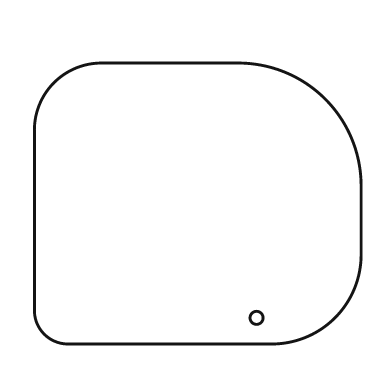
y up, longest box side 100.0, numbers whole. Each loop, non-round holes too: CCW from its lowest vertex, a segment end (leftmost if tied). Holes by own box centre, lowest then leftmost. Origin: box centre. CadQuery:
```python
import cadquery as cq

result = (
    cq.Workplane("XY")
    .moveTo(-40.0, -43.0)
    .lineTo(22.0, -43.0)
    .threePointArc((42.0, -35.0), (50.0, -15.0))
    .lineTo(50.0, 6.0)
    .threePointArc((39.0, 32.0), (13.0, 43.0))
    .lineTo(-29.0, 43.0)
    .threePointArc((-44.0, 37.0), (-50.0, 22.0))
    .lineTo(-50.0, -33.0)
    .threePointArc((-47.0, -40.0), (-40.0, -43.0))
    .close()
    .moveTo(18.0, -35.0)
    .circle(2.0)
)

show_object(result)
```